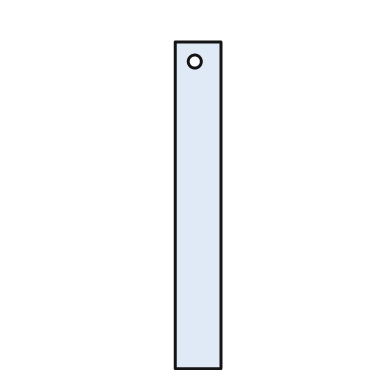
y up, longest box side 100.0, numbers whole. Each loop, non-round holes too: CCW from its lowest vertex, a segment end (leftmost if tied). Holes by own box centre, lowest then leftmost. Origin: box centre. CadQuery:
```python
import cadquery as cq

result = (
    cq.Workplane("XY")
    .moveTo(-7.0, -50.0)
    .lineTo(7.0, -50.0)
    .lineTo(7.0, 50.0)
    .lineTo(-7.0, 50.0)
    .close()
    .moveTo(-1.0, 44.0)
    .circle(2.0)
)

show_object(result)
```